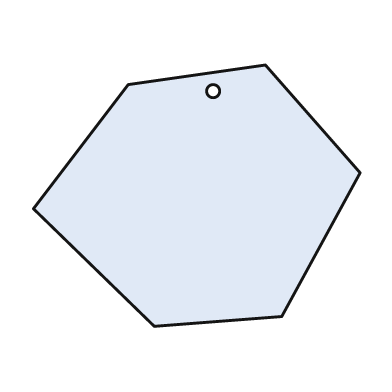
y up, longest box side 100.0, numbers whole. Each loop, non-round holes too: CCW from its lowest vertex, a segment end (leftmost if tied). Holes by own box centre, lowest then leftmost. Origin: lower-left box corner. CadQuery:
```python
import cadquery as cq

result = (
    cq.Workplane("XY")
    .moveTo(37.0, 0.0)
    .lineTo(76.0, 3.0)
    .lineTo(100.0, 47.0)
    .lineTo(71.0, 80.0)
    .lineTo(29.0, 74.0)
    .lineTo(0.0, 36.0)
    .close()
    .moveTo(55.0, 72.0)
    .circle(2.0)
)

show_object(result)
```